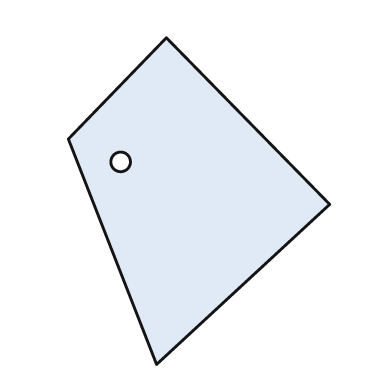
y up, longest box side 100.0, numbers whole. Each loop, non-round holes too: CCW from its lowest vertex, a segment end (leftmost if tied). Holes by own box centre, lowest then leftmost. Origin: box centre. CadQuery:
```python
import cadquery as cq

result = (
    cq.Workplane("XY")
    .moveTo(-13.0, -50.0)
    .lineTo(40.0, -1.0)
    .lineTo(-10.0, 50.0)
    .lineTo(-40.0, 19.0)
    .close()
    .moveTo(-24.0, 12.0)
    .circle(3.0)
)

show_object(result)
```